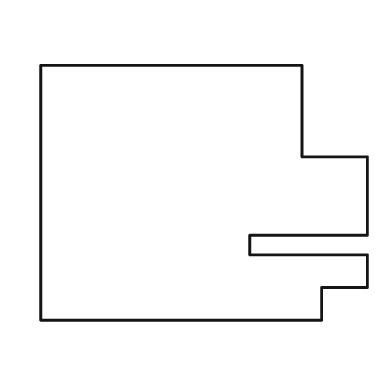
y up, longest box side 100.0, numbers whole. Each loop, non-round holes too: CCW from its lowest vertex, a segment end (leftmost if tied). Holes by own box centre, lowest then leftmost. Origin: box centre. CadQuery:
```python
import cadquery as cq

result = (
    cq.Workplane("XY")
    .moveTo(-50.0, -39.0)
    .lineTo(36.0, -39.0)
    .lineTo(36.0, -29.0)
    .lineTo(50.0, -29.0)
    .lineTo(50.0, -19.0)
    .lineTo(14.0, -19.0)
    .lineTo(14.0, -13.0)
    .lineTo(50.0, -13.0)
    .lineTo(50.0, 11.0)
    .lineTo(30.0, 11.0)
    .lineTo(30.0, 39.0)
    .lineTo(-50.0, 39.0)
    .close()
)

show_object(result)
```